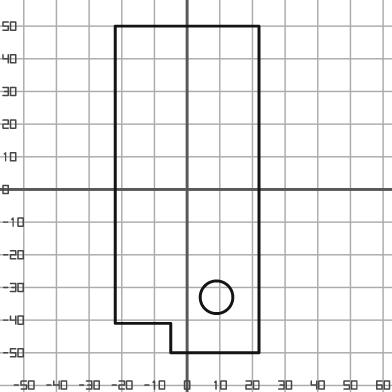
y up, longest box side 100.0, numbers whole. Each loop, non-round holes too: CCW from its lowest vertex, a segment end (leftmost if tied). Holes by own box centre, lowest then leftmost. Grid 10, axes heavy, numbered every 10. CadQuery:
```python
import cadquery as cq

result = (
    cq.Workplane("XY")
    .moveTo(-5.0, -50.0)
    .lineTo(22.0, -50.0)
    .lineTo(22.0, 50.0)
    .lineTo(-22.0, 50.0)
    .lineTo(-22.0, -41.0)
    .lineTo(-5.0, -41.0)
    .close()
    .moveTo(9.0, -33.0)
    .circle(5.0)
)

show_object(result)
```